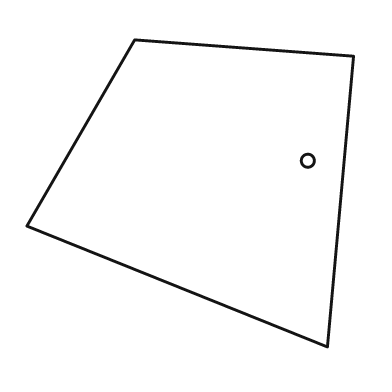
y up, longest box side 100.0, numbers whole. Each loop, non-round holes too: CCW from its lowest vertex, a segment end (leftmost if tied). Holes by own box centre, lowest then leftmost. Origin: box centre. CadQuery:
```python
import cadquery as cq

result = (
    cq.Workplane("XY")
    .moveTo(42.0, -47.0)
    .lineTo(50.0, 42.0)
    .lineTo(-17.0, 47.0)
    .lineTo(-50.0, -10.0)
    .close()
    .moveTo(36.0, 10.0)
    .circle(2.0)
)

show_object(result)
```